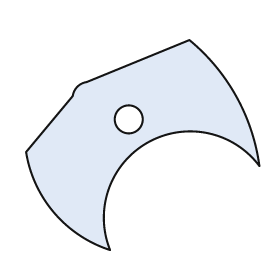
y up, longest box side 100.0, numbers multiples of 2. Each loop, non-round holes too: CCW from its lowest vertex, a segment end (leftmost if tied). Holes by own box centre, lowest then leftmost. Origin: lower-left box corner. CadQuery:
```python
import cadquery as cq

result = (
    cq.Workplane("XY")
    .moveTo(36.0, 0.0)
    .threePointArc((52.0, 46.0), (100.0, 36.0))
    .threePointArc((90.0, 66.0), (70.0, 90.0))
    .lineTo(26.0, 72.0)
    .threePointArc((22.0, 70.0), (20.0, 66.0))
    .lineTo(0.0, 42.0)
    .threePointArc((12.0, 16.0), (36.0, 0.0))
    .close()
    .moveTo(44.0, 56.0)
    .circle(6.0)
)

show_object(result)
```